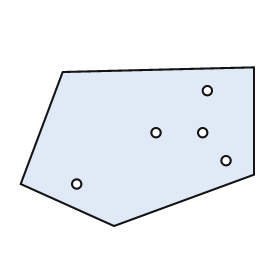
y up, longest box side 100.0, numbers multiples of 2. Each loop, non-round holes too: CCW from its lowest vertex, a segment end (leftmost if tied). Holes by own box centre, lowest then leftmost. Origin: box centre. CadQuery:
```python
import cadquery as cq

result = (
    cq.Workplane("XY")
    .moveTo(-10.0, -34.0)
    .lineTo(50.0, -12.0)
    .lineTo(50.0, 34.0)
    .lineTo(-32.0, 32.0)
    .lineTo(-50.0, -16.0)
    .close()
    .moveTo(-26.0, -16.0)
    .circle(2.0)
    .moveTo(38.0, -6.0)
    .circle(2.0)
    .moveTo(8.0, 6.0)
    .circle(2.0)
    .moveTo(28.0, 6.0)
    .circle(2.0)
    .moveTo(30.0, 24.0)
    .circle(2.0)
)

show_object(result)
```